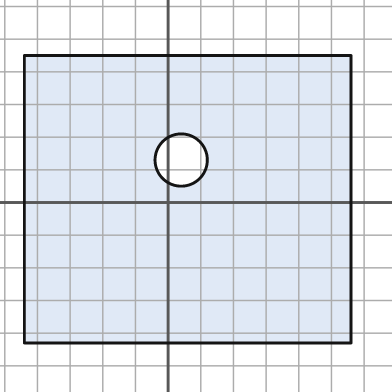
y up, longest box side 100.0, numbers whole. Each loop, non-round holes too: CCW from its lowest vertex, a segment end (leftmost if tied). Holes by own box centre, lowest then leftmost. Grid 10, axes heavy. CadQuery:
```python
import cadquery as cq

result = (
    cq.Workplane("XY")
    .moveTo(-44.0, -43.0)
    .lineTo(56.0, -43.0)
    .lineTo(56.0, 45.0)
    .lineTo(-44.0, 45.0)
    .close()
    .moveTo(4.0, 13.0)
    .circle(8.0)
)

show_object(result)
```